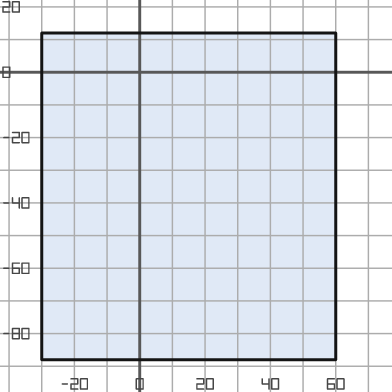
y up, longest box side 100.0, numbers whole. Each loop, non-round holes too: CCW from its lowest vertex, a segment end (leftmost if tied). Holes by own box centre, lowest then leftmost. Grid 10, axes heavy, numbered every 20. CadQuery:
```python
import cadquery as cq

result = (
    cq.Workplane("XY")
    .moveTo(-30.0, -88.0)
    .lineTo(60.0, -88.0)
    .lineTo(60.0, 12.0)
    .lineTo(-30.0, 12.0)
    .close()
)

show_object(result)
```